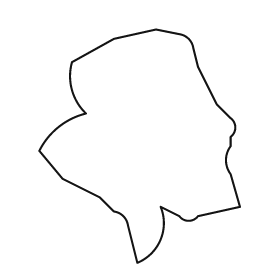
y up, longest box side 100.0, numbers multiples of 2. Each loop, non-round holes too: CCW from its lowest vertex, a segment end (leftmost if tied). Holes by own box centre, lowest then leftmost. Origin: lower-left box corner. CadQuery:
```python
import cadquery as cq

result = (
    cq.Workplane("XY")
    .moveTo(42.0, 0.0)
    .threePointArc((52.0, 10.0), (52.0, 24.0))
    .lineTo(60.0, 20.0)
    .threePointArc((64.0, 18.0), (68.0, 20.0))
    .lineTo(86.0, 24.0)
    .lineTo(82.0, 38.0)
    .threePointArc((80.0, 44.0), (82.0, 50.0))
    .lineTo(82.0, 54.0)
    .threePointArc((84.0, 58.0), (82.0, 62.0))
    .lineTo(76.0, 68.0)
    .lineTo(68.0, 84.0)
    .lineTo(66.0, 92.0)
    .threePointArc((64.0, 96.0), (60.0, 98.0))
    .lineTo(50.0, 100.0)
    .lineTo(32.0, 96.0)
    .lineTo(14.0, 86.0)
    .threePointArc((14.0, 74.0), (20.0, 64.0))
    .threePointArc((8.0, 58.0), (0.0, 48.0))
    .lineTo(10.0, 36.0)
    .lineTo(26.0, 28.0)
    .lineTo(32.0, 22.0)
    .threePointArc((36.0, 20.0), (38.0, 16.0))
    .close()
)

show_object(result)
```